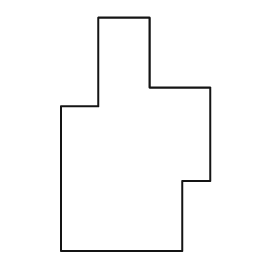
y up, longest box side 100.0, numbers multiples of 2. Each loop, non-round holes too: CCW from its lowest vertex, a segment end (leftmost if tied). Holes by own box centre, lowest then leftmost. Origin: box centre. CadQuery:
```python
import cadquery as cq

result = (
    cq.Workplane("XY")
    .moveTo(-32.0, -50.0)
    .lineTo(20.0, -50.0)
    .lineTo(20.0, -20.0)
    .lineTo(32.0, -20.0)
    .lineTo(32.0, 20.0)
    .lineTo(6.0, 20.0)
    .lineTo(6.0, 50.0)
    .lineTo(-16.0, 50.0)
    .lineTo(-16.0, 12.0)
    .lineTo(-32.0, 12.0)
    .close()
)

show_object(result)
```